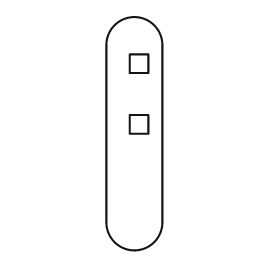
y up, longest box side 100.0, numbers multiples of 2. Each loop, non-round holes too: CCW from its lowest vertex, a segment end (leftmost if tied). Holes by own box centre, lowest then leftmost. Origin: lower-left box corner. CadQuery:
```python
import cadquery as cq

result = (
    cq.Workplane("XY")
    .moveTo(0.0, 12.0)
    .threePointArc((12.0, 0.0), (24.0, 12.0))
    .lineTo(24.0, 88.0)
    .threePointArc((12.0, 100.0), (0.0, 88.0))
    .close()
    .moveTo(10.0, 50.0)
    .lineTo(18.0, 50.0)
    .lineTo(18.0, 58.0)
    .lineTo(10.0, 58.0)
    .close()
    .moveTo(10.0, 76.0)
    .lineTo(18.0, 76.0)
    .lineTo(18.0, 84.0)
    .lineTo(10.0, 84.0)
    .close()
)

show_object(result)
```